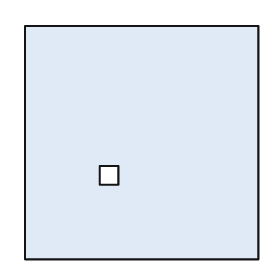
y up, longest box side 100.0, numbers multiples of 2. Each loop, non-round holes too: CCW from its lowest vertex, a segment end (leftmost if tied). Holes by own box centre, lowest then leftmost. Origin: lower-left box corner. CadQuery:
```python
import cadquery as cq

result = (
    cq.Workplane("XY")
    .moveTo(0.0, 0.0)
    .lineTo(100.0, 0.0)
    .lineTo(100.0, 100.0)
    .lineTo(0.0, 100.0)
    .close()
    .moveTo(32.0, 32.0)
    .lineTo(40.0, 32.0)
    .lineTo(40.0, 40.0)
    .lineTo(32.0, 40.0)
    .close()
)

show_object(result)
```